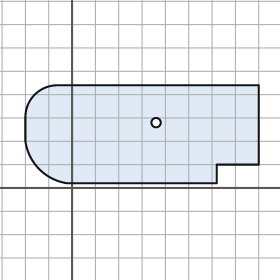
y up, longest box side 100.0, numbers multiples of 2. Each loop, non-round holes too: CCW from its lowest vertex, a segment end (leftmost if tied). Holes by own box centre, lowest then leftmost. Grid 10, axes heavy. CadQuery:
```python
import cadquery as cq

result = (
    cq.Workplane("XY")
    .moveTo(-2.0, 2.0)
    .lineTo(62.0, 2.0)
    .lineTo(62.0, 10.0)
    .lineTo(80.0, 10.0)
    .lineTo(80.0, 44.0)
    .lineTo(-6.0, 44.0)
    .threePointArc((-16.0, 40.0), (-20.0, 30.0))
    .lineTo(-20.0, 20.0)
    .threePointArc((-14.0, 8.0), (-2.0, 2.0))
    .close()
    .moveTo(36.0, 28.0)
    .circle(2.0)
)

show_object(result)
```